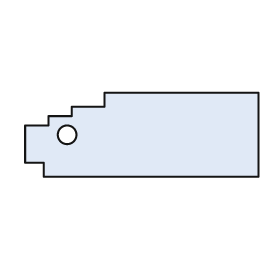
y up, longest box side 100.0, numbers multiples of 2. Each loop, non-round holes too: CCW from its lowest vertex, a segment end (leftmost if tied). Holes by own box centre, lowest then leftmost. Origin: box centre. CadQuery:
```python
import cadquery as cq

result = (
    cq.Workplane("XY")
    .moveTo(-42.0, -18.0)
    .lineTo(50.0, -18.0)
    .lineTo(50.0, 18.0)
    .lineTo(-16.0, 18.0)
    .lineTo(-16.0, 12.0)
    .lineTo(-30.0, 12.0)
    .lineTo(-30.0, 8.0)
    .lineTo(-40.0, 8.0)
    .lineTo(-40.0, 4.0)
    .lineTo(-50.0, 4.0)
    .lineTo(-50.0, -12.0)
    .lineTo(-42.0, -12.0)
    .close()
    .moveTo(-32.0, 0.0)
    .circle(4.0)
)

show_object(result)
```